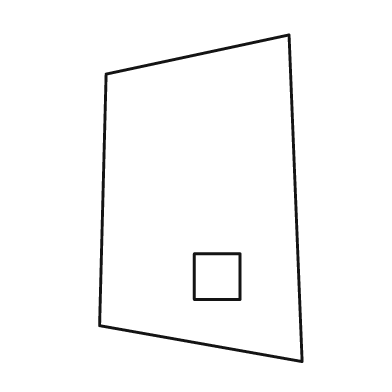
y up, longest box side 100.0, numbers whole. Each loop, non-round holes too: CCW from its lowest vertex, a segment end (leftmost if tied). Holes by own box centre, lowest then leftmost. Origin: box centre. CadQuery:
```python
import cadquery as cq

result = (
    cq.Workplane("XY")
    .moveTo(31.0, -50.0)
    .lineTo(27.0, 50.0)
    .lineTo(-29.0, 38.0)
    .lineTo(-31.0, -39.0)
    .close()
    .moveTo(-2.0, -31.0)
    .lineTo(12.0, -31.0)
    .lineTo(12.0, -17.0)
    .lineTo(-2.0, -17.0)
    .close()
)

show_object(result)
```